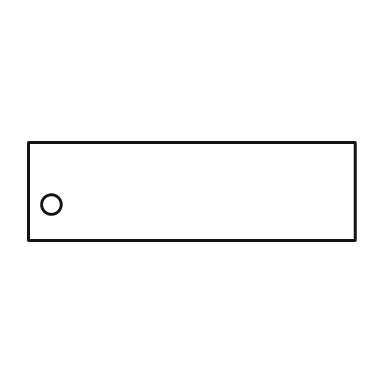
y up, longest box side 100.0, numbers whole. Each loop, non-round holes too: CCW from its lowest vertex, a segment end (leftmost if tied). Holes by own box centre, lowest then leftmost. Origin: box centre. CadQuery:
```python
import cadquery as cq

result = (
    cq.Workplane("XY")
    .moveTo(-50.0, -15.0)
    .lineTo(50.0, -15.0)
    .lineTo(50.0, 15.0)
    .lineTo(-50.0, 15.0)
    .close()
    .moveTo(-43.0, -4.0)
    .circle(3.0)
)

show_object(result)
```